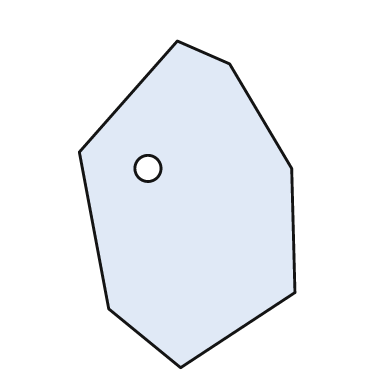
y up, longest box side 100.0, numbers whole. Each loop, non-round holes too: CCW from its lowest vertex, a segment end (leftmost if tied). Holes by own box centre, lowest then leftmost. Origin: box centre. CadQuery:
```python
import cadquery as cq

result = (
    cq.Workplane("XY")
    .moveTo(-2.0, -50.0)
    .lineTo(33.0, -27.0)
    .lineTo(32.0, 11.0)
    .lineTo(13.0, 43.0)
    .lineTo(-3.0, 50.0)
    .lineTo(-33.0, 16.0)
    .lineTo(-24.0, -32.0)
    .close()
    .moveTo(-12.0, 11.0)
    .circle(4.0)
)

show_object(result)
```